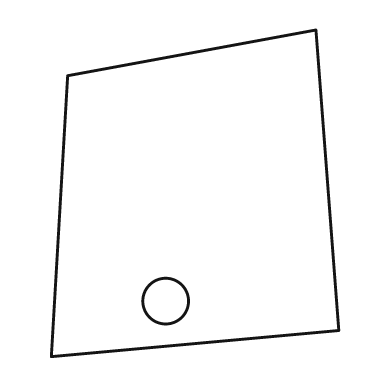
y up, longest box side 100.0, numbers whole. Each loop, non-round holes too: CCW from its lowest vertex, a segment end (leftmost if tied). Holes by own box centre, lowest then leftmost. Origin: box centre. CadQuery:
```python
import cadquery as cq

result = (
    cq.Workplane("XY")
    .moveTo(-44.0, -50.0)
    .lineTo(44.0, -42.0)
    .lineTo(37.0, 50.0)
    .lineTo(-39.0, 36.0)
    .close()
    .moveTo(-9.0, -33.0)
    .circle(7.0)
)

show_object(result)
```